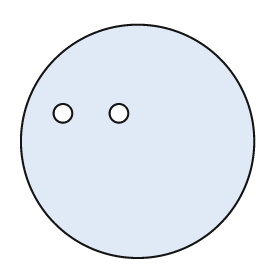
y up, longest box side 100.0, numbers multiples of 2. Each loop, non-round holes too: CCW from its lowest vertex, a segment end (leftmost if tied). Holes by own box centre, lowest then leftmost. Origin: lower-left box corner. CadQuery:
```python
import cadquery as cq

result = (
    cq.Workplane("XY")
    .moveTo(50.0, 50.0)
    .circle(50.0)
    .moveTo(18.0, 62.0)
    .circle(4.0)
    .moveTo(42.0, 62.0)
    .circle(4.0)
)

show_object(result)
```